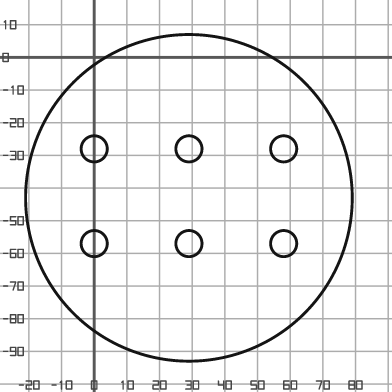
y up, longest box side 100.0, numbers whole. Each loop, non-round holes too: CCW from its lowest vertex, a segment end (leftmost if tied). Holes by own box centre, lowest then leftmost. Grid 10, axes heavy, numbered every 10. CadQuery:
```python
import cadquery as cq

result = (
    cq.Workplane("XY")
    .moveTo(29.0, -43.0)
    .circle(50.0)
    .moveTo(0.0, -57.0)
    .circle(4.0)
    .moveTo(29.0, -57.0)
    .circle(4.0)
    .moveTo(58.0, -57.0)
    .circle(4.0)
    .moveTo(0.0, -28.0)
    .circle(4.0)
    .moveTo(29.0, -28.0)
    .circle(4.0)
    .moveTo(58.0, -28.0)
    .circle(4.0)
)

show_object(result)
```